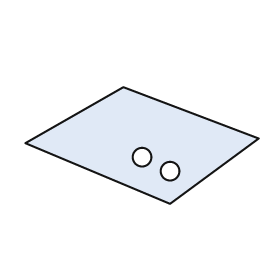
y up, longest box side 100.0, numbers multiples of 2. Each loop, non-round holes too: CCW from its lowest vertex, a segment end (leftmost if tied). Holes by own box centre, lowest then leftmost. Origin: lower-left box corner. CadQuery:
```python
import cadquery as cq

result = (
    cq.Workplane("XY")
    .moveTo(62.0, 0.0)
    .lineTo(100.0, 28.0)
    .lineTo(42.0, 50.0)
    .lineTo(0.0, 26.0)
    .close()
    .moveTo(62.0, 14.0)
    .circle(4.0)
    .moveTo(50.0, 20.0)
    .circle(4.0)
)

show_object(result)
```